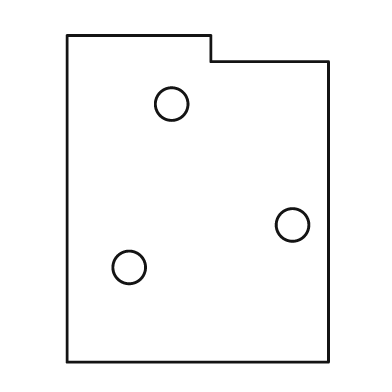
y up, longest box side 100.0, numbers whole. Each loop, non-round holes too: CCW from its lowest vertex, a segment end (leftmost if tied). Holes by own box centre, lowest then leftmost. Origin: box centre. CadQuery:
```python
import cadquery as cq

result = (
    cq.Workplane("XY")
    .moveTo(-40.0, -50.0)
    .lineTo(40.0, -50.0)
    .lineTo(40.0, 42.0)
    .lineTo(4.0, 42.0)
    .lineTo(4.0, 50.0)
    .lineTo(-40.0, 50.0)
    .close()
    .moveTo(-21.0, -21.0)
    .circle(5.0)
    .moveTo(29.0, -8.0)
    .circle(5.0)
    .moveTo(-8.0, 29.0)
    .circle(5.0)
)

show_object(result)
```